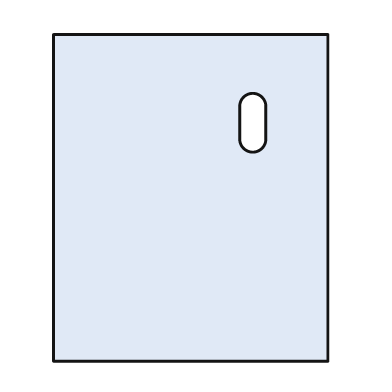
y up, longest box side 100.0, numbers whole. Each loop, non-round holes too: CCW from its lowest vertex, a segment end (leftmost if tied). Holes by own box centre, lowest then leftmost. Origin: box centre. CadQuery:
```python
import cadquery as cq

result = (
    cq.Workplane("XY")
    .moveTo(-42.0, -50.0)
    .lineTo(42.0, -50.0)
    .lineTo(42.0, 50.0)
    .lineTo(-42.0, 50.0)
    .close()
    .moveTo(15.0, 18.0)
    .threePointArc((19.0, 14.0), (23.0, 18.0))
    .lineTo(23.0, 28.0)
    .threePointArc((19.0, 32.0), (15.0, 28.0))
    .close()
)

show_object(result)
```